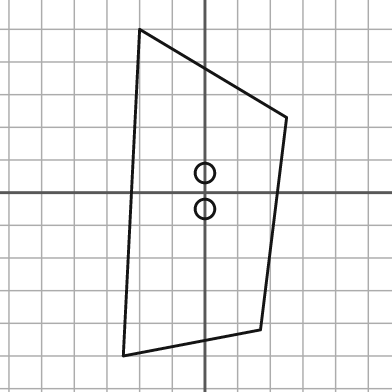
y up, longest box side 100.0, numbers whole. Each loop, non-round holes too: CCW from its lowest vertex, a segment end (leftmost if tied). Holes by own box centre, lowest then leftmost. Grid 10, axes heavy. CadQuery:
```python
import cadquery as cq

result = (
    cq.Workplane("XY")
    .moveTo(-25.0, -50.0)
    .lineTo(17.0, -42.0)
    .lineTo(25.0, 23.0)
    .lineTo(-20.0, 50.0)
    .close()
    .moveTo(0.0, -5.0)
    .circle(3.0)
    .moveTo(0.0, 6.0)
    .circle(3.0)
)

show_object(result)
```